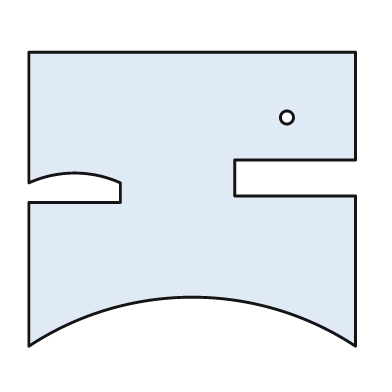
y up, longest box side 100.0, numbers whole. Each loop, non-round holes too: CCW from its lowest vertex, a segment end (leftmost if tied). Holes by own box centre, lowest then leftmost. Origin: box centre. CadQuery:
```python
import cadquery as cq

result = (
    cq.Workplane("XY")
    .moveTo(-50.0, -45.0)
    .threePointArc((0.0, -30.0), (50.0, -45.0))
    .lineTo(50.0, 1.0)
    .lineTo(13.0, 1.0)
    .lineTo(13.0, 12.0)
    .lineTo(50.0, 12.0)
    .lineTo(50.0, 45.0)
    .lineTo(-50.0, 45.0)
    .lineTo(-50.0, 5.0)
    .threePointArc((-36.0, 8.0), (-22.0, 5.0))
    .lineTo(-22.0, -1.0)
    .lineTo(-50.0, -1.0)
    .close()
    .moveTo(29.0, 25.0)
    .circle(2.0)
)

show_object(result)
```